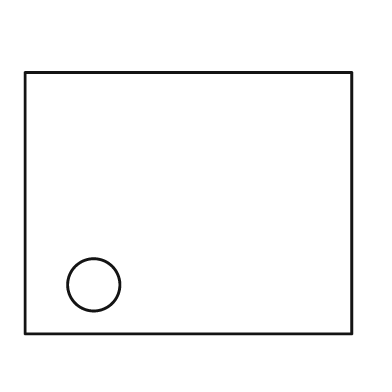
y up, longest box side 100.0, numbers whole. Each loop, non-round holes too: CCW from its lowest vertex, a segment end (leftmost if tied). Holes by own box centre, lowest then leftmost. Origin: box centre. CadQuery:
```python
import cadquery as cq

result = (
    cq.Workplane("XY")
    .moveTo(-50.0, -40.0)
    .lineTo(50.0, -40.0)
    .lineTo(50.0, 40.0)
    .lineTo(-50.0, 40.0)
    .close()
    .moveTo(-29.0, -25.0)
    .circle(8.0)
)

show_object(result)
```